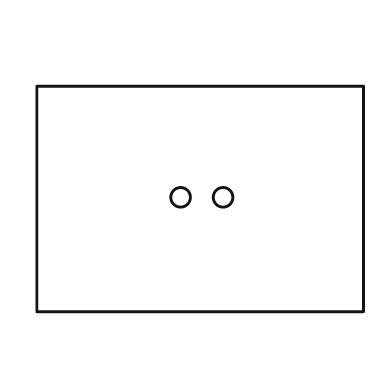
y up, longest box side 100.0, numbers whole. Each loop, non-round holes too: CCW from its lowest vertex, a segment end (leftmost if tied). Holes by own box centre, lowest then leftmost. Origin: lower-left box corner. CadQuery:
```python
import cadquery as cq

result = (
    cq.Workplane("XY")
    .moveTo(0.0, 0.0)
    .lineTo(100.0, 0.0)
    .lineTo(100.0, 69.0)
    .lineTo(0.0, 69.0)
    .close()
    .moveTo(44.0, 35.0)
    .circle(3.0)
    .moveTo(57.0, 35.0)
    .circle(3.0)
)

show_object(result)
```